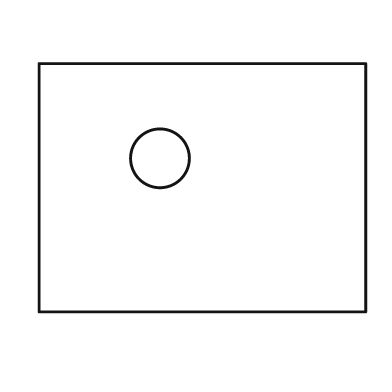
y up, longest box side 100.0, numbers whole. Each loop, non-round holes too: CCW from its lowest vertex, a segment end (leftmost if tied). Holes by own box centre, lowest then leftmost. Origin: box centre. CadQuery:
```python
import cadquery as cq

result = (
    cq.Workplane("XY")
    .moveTo(-50.0, -38.0)
    .lineTo(50.0, -38.0)
    .lineTo(50.0, 38.0)
    .lineTo(-50.0, 38.0)
    .close()
    .moveTo(-13.0, 9.0)
    .circle(9.0)
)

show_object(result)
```